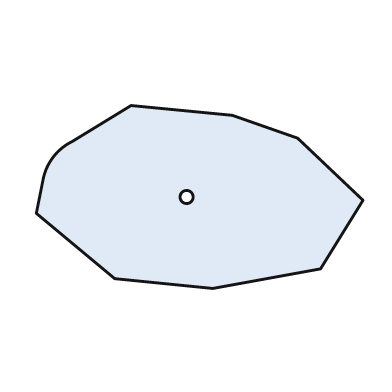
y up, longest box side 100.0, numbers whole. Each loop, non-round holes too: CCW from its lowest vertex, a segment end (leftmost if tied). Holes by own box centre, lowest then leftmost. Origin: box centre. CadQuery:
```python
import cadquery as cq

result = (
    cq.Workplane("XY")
    .moveTo(4.0, -28.0)
    .lineTo(37.0, -22.0)
    .lineTo(50.0, -1.0)
    .lineTo(30.0, 18.0)
    .lineTo(10.0, 25.0)
    .lineTo(-21.0, 28.0)
    .lineTo(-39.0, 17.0)
    .threePointArc((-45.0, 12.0), (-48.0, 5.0))
    .lineTo(-50.0, -5.0)
    .lineTo(-26.0, -25.0)
    .close()
    .moveTo(-4.0, 0.0)
    .circle(2.0)
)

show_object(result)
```